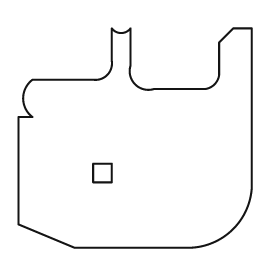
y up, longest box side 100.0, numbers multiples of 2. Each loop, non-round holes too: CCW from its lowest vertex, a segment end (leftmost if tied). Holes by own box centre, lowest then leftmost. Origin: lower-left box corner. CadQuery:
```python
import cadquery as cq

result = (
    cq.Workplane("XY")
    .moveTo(24.0, 0.0)
    .lineTo(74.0, 0.0)
    .threePointArc((92.0, 8.0), (100.0, 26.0))
    .lineTo(100.0, 94.0)
    .lineTo(92.0, 94.0)
    .lineTo(86.0, 88.0)
    .lineTo(86.0, 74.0)
    .threePointArc((84.0, 70.0), (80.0, 68.0))
    .lineTo(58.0, 68.0)
    .threePointArc((50.0, 70.0), (48.0, 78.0))
    .lineTo(48.0, 94.0)
    .threePointArc((44.0, 92.0), (40.0, 94.0))
    .lineTo(40.0, 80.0)
    .threePointArc((38.0, 74.0), (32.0, 72.0))
    .lineTo(6.0, 72.0)
    .threePointArc((2.0, 64.0), (6.0, 56.0))
    .lineTo(0.0, 56.0)
    .lineTo(0.0, 10.0)
    .close()
    .moveTo(32.0, 28.0)
    .lineTo(40.0, 28.0)
    .lineTo(40.0, 36.0)
    .lineTo(32.0, 36.0)
    .close()
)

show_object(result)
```